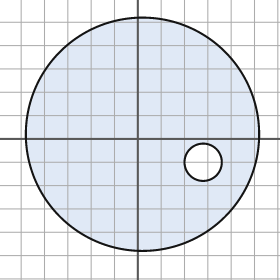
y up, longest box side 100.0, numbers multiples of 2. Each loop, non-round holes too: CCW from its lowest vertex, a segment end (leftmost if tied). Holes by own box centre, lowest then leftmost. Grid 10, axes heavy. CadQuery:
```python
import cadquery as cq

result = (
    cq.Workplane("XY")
    .moveTo(2.0, 2.0)
    .circle(50.0)
    .moveTo(28.0, -10.0)
    .circle(8.0)
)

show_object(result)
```